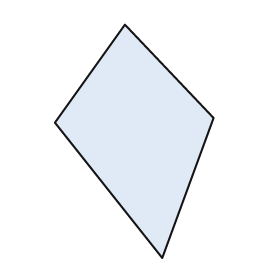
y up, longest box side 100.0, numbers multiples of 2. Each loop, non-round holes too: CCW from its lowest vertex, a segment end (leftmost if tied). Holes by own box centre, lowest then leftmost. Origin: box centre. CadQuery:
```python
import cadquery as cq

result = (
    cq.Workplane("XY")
    .moveTo(12.0, -50.0)
    .lineTo(34.0, 10.0)
    .lineTo(-4.0, 50.0)
    .lineTo(-34.0, 8.0)
    .close()
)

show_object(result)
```